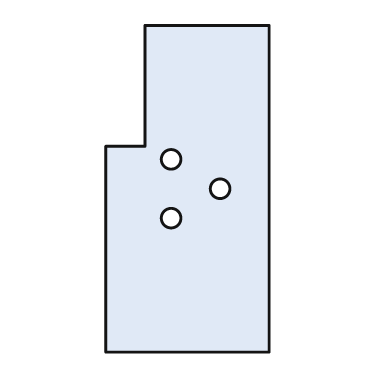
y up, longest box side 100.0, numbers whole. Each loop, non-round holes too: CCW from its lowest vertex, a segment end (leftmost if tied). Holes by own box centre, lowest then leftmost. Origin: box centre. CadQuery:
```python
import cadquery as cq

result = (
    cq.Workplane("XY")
    .moveTo(-25.0, -50.0)
    .lineTo(25.0, -50.0)
    .lineTo(25.0, 50.0)
    .lineTo(-13.0, 50.0)
    .lineTo(-13.0, 13.0)
    .lineTo(-25.0, 13.0)
    .close()
    .moveTo(-5.0, -9.0)
    .circle(3.0)
    .moveTo(10.0, 0.0)
    .circle(3.0)
    .moveTo(-5.0, 9.0)
    .circle(3.0)
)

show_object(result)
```